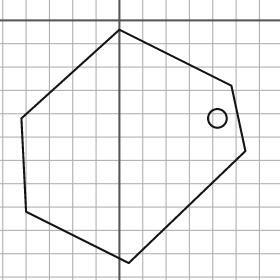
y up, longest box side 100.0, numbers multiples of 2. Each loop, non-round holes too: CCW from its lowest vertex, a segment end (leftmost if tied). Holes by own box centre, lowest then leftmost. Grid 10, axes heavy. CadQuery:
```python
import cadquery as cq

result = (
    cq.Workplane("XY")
    .moveTo(4.0, -104.0)
    .lineTo(54.0, -56.0)
    .lineTo(48.0, -28.0)
    .lineTo(0.0, -4.0)
    .lineTo(-42.0, -42.0)
    .lineTo(-40.0, -82.0)
    .close()
    .moveTo(42.0, -42.0)
    .circle(4.0)
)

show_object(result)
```